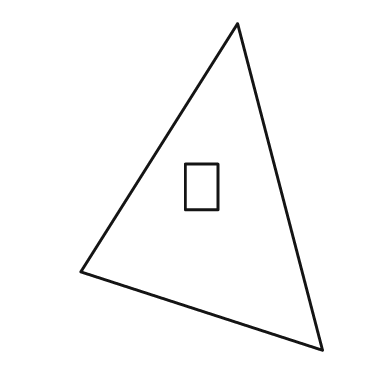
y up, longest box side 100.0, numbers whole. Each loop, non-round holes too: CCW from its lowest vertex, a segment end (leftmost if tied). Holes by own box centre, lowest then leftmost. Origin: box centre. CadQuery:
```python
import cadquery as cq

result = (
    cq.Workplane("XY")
    .moveTo(37.0, -50.0)
    .lineTo(11.0, 50.0)
    .lineTo(-37.0, -26.0)
    .close()
    .moveTo(-5.0, -7.0)
    .lineTo(5.0, -7.0)
    .lineTo(5.0, 7.0)
    .lineTo(-5.0, 7.0)
    .close()
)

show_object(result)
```